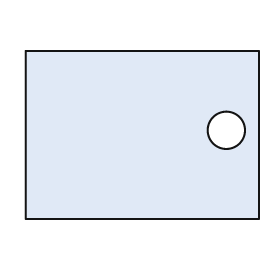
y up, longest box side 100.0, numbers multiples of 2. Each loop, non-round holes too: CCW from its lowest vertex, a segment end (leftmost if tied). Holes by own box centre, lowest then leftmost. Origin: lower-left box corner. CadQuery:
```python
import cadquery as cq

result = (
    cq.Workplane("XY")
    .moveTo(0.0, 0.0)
    .lineTo(100.0, 0.0)
    .lineTo(100.0, 72.0)
    .lineTo(0.0, 72.0)
    .close()
    .moveTo(86.0, 38.0)
    .circle(8.0)
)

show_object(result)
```